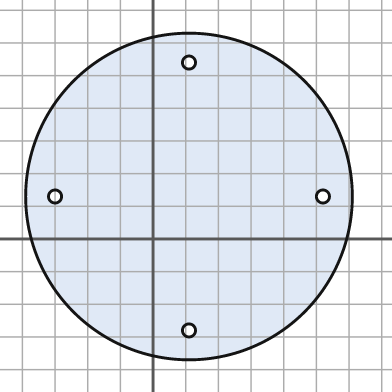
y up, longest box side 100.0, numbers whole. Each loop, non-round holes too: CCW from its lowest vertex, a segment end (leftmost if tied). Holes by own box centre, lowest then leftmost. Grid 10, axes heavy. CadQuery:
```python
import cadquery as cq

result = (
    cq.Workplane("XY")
    .moveTo(11.0, 13.0)
    .circle(50.0)
    .moveTo(11.0, -28.0)
    .circle(2.0)
    .moveTo(-30.0, 13.0)
    .circle(2.0)
    .moveTo(52.0, 13.0)
    .circle(2.0)
    .moveTo(11.0, 54.0)
    .circle(2.0)
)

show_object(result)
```